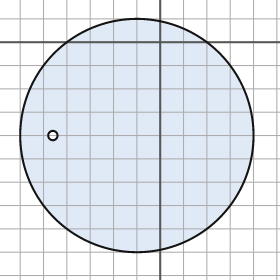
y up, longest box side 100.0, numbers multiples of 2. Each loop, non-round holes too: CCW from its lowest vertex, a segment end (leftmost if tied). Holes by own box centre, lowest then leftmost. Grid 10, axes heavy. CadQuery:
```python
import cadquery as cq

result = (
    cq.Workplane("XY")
    .moveTo(-10.0, -40.0)
    .circle(50.0)
    .moveTo(-46.0, -40.0)
    .circle(2.0)
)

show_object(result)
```